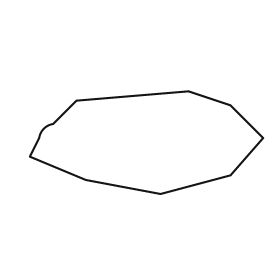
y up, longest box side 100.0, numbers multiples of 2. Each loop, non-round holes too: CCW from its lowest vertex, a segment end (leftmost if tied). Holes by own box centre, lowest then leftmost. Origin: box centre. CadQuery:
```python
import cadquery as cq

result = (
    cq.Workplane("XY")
    .moveTo(6.0, -22.0)
    .lineTo(36.0, -14.0)
    .lineTo(50.0, 2.0)
    .lineTo(36.0, 16.0)
    .lineTo(18.0, 22.0)
    .lineTo(-30.0, 18.0)
    .lineTo(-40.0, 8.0)
    .threePointArc((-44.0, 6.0), (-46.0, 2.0))
    .lineTo(-50.0, -6.0)
    .lineTo(-26.0, -16.0)
    .close()
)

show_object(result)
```